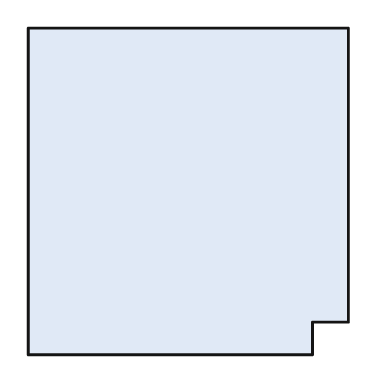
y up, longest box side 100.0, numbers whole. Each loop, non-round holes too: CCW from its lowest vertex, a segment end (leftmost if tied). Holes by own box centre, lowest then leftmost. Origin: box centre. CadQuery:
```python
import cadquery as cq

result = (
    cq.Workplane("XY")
    .moveTo(-49.0, -50.0)
    .lineTo(38.0, -50.0)
    .lineTo(38.0, -40.0)
    .lineTo(49.0, -40.0)
    .lineTo(49.0, 50.0)
    .lineTo(-49.0, 50.0)
    .close()
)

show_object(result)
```